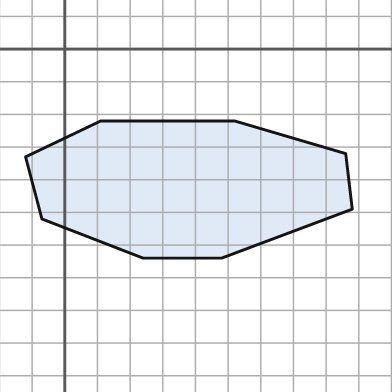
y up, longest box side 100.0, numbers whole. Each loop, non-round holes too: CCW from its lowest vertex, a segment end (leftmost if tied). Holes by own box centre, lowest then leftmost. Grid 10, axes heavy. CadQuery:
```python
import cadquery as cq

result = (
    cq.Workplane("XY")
    .moveTo(24.0, -64.0)
    .lineTo(48.0, -64.0)
    .lineTo(88.0, -49.0)
    .lineTo(86.0, -32.0)
    .lineTo(52.0, -22.0)
    .lineTo(11.0, -22.0)
    .lineTo(-12.0, -33.0)
    .lineTo(-7.0, -52.0)
    .close()
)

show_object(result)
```